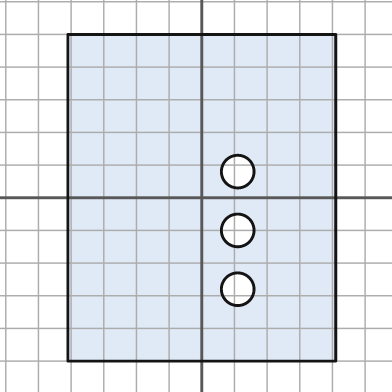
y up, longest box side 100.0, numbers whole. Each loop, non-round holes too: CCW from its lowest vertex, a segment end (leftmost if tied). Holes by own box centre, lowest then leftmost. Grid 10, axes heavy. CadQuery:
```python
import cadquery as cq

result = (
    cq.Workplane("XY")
    .moveTo(-41.0, -50.0)
    .lineTo(41.0, -50.0)
    .lineTo(41.0, 50.0)
    .lineTo(-41.0, 50.0)
    .close()
    .moveTo(11.0, -28.0)
    .circle(5.0)
    .moveTo(11.0, -10.0)
    .circle(5.0)
    .moveTo(11.0, 8.0)
    .circle(5.0)
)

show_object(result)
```